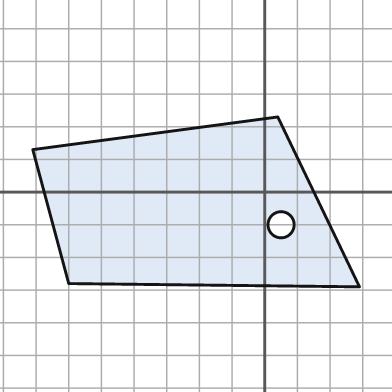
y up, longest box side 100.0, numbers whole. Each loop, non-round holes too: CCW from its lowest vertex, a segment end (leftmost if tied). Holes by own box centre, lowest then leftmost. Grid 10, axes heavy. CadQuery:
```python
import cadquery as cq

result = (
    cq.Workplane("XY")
    .moveTo(29.0, -29.0)
    .lineTo(4.0, 23.0)
    .lineTo(-71.0, 13.0)
    .lineTo(-60.0, -28.0)
    .close()
    .moveTo(5.0, -10.0)
    .circle(4.0)
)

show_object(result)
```